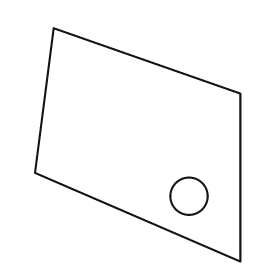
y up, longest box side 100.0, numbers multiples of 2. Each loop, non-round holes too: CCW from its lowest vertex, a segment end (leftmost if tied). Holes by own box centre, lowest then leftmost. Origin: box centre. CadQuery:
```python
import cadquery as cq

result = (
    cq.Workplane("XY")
    .moveTo(44.0, -50.0)
    .lineTo(44.0, 22.0)
    .lineTo(-36.0, 50.0)
    .lineTo(-44.0, -12.0)
    .close()
    .moveTo(22.0, -22.0)
    .circle(8.0)
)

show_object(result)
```